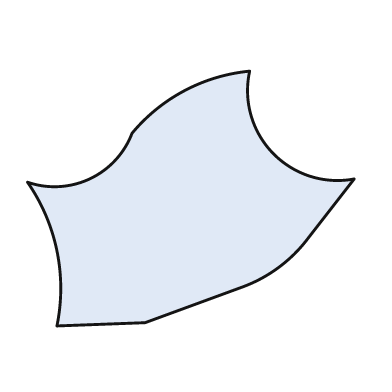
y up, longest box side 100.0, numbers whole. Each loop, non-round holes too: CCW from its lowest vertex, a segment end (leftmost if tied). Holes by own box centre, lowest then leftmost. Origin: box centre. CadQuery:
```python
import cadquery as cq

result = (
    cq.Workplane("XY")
    .moveTo(-41.0, -39.0)
    .lineTo(-14.0, -38.0)
    .lineTo(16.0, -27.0)
    .threePointArc((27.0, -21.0), (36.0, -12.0))
    .lineTo(50.0, 6.0)
    .threePointArc((25.0, 14.0), (18.0, 39.0))
    .threePointArc((-2.0, 33.0), (-18.0, 20.0))
    .threePointArc((-31.0, 6.0), (-50.0, 5.0))
    .threePointArc((-41.0, -16.0), (-41.0, -39.0))
    .close()
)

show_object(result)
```